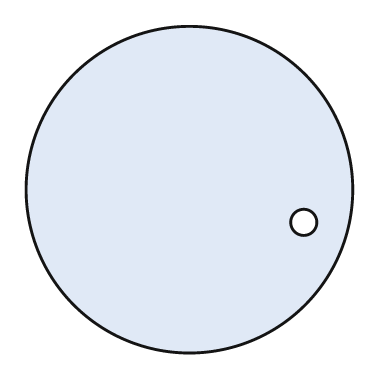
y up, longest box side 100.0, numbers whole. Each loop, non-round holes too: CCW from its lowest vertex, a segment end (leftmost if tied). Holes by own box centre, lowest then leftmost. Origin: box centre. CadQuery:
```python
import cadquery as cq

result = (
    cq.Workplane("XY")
    .moveTo(0.0, 0.0)
    .circle(50.0)
    .moveTo(35.0, -10.0)
    .circle(4.0)
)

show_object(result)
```